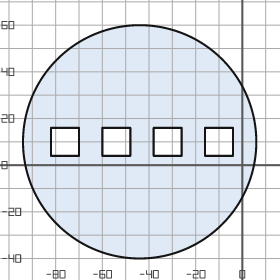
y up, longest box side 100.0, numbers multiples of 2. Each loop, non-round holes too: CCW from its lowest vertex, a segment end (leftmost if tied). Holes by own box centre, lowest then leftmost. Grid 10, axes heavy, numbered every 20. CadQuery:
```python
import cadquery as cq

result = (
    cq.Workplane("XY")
    .moveTo(-44.0, 10.0)
    .circle(50.0)
    .moveTo(-82.0, 4.0)
    .lineTo(-70.0, 4.0)
    .lineTo(-70.0, 16.0)
    .lineTo(-82.0, 16.0)
    .close()
    .moveTo(-60.0, 4.0)
    .lineTo(-48.0, 4.0)
    .lineTo(-48.0, 16.0)
    .lineTo(-60.0, 16.0)
    .close()
    .moveTo(-38.0, 4.0)
    .lineTo(-26.0, 4.0)
    .lineTo(-26.0, 16.0)
    .lineTo(-38.0, 16.0)
    .close()
    .moveTo(-16.0, 4.0)
    .lineTo(-4.0, 4.0)
    .lineTo(-4.0, 16.0)
    .lineTo(-16.0, 16.0)
    .close()
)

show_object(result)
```